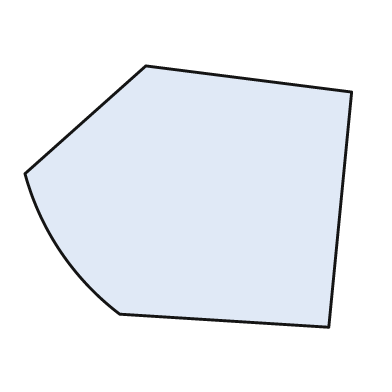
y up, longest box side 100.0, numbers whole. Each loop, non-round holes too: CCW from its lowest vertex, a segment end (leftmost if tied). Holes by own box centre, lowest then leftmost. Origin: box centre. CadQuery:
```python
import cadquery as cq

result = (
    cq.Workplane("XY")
    .moveTo(43.0, -40.0)
    .lineTo(50.0, 32.0)
    .lineTo(-13.0, 40.0)
    .lineTo(-50.0, 7.0)
    .threePointArc((-39.0, -17.0), (-21.0, -36.0))
    .close()
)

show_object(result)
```